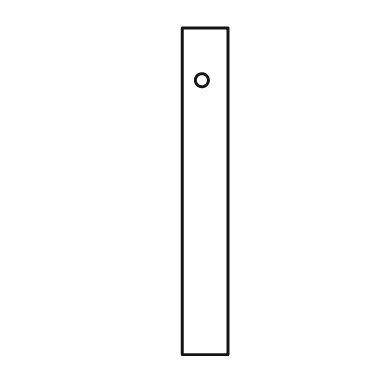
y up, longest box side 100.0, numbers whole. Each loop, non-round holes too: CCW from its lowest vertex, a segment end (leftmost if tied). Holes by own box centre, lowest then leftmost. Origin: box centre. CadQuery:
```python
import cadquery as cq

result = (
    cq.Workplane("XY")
    .moveTo(-7.0, -50.0)
    .lineTo(7.0, -50.0)
    .lineTo(7.0, 50.0)
    .lineTo(-7.0, 50.0)
    .close()
    .moveTo(-1.0, 34.0)
    .circle(2.0)
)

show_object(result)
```